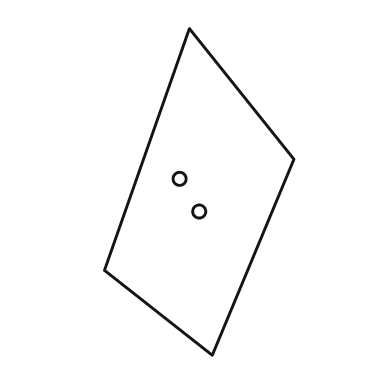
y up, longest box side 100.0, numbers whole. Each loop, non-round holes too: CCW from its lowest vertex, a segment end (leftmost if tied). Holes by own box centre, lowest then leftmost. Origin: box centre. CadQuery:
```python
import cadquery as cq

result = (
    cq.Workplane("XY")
    .moveTo(4.0, -50.0)
    .lineTo(29.0, 10.0)
    .lineTo(-3.0, 50.0)
    .lineTo(-29.0, -24.0)
    .close()
    .moveTo(0.0, -6.0)
    .circle(2.0)
    .moveTo(-6.0, 4.0)
    .circle(2.0)
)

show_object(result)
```